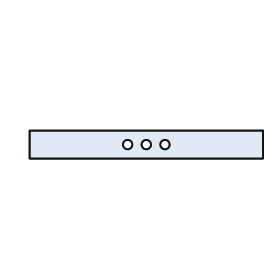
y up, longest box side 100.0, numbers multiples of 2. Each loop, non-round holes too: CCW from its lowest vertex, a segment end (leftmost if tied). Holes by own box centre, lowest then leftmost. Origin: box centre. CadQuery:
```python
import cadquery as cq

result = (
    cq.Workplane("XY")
    .moveTo(-50.0, -6.0)
    .lineTo(50.0, -6.0)
    .lineTo(50.0, 6.0)
    .lineTo(-50.0, 6.0)
    .close()
    .moveTo(-8.0, 0.0)
    .circle(2.0)
    .moveTo(0.0, 0.0)
    .circle(2.0)
    .moveTo(8.0, 0.0)
    .circle(2.0)
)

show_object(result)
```